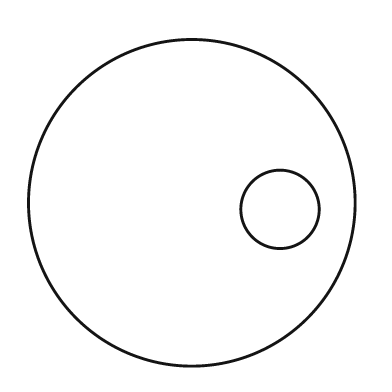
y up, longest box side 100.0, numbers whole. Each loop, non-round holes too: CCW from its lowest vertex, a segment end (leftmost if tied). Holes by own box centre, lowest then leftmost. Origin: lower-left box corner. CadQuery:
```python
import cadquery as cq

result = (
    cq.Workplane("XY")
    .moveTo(50.0, 50.0)
    .circle(50.0)
    .moveTo(77.0, 48.0)
    .circle(12.0)
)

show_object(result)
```